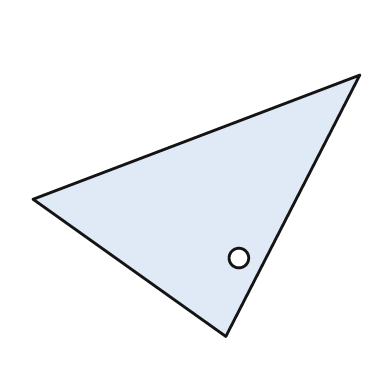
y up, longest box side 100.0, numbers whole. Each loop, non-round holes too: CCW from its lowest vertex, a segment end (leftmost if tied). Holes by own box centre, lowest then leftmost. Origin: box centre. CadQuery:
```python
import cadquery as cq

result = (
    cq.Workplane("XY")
    .moveTo(9.0, -40.0)
    .lineTo(50.0, 40.0)
    .lineTo(-50.0, 2.0)
    .close()
    .moveTo(13.0, -16.0)
    .circle(3.0)
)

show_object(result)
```